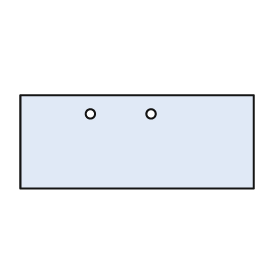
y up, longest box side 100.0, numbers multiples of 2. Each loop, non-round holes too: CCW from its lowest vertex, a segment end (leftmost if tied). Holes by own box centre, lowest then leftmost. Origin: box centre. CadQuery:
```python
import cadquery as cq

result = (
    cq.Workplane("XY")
    .moveTo(-50.0, -20.0)
    .lineTo(50.0, -20.0)
    .lineTo(50.0, 20.0)
    .lineTo(-50.0, 20.0)
    .close()
    .moveTo(-20.0, 12.0)
    .circle(2.0)
    .moveTo(6.0, 12.0)
    .circle(2.0)
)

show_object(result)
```